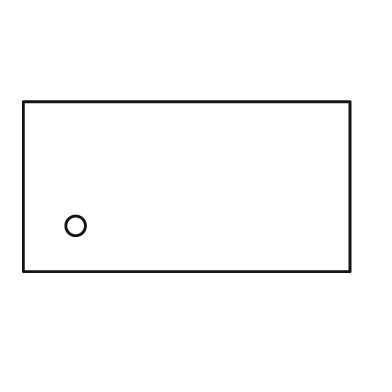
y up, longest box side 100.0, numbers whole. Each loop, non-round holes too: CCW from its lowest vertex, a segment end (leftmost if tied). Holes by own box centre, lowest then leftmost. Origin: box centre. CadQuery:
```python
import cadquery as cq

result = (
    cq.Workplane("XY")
    .moveTo(-50.0, -26.0)
    .lineTo(50.0, -26.0)
    .lineTo(50.0, 26.0)
    .lineTo(-50.0, 26.0)
    .close()
    .moveTo(-34.0, -12.0)
    .circle(3.0)
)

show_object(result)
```